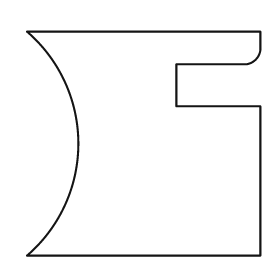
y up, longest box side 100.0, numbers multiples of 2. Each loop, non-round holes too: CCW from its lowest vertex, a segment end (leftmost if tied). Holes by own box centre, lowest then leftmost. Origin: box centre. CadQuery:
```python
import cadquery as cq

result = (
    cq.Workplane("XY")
    .moveTo(-50.0, -48.0)
    .lineTo(50.0, -48.0)
    .lineTo(50.0, 16.0)
    .lineTo(14.0, 16.0)
    .lineTo(14.0, 34.0)
    .lineTo(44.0, 34.0)
    .threePointArc((48.0, 36.0), (50.0, 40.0))
    .lineTo(50.0, 48.0)
    .lineTo(-50.0, 48.0)
    .threePointArc((-28.0, 0.0), (-50.0, -48.0))
    .close()
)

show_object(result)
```